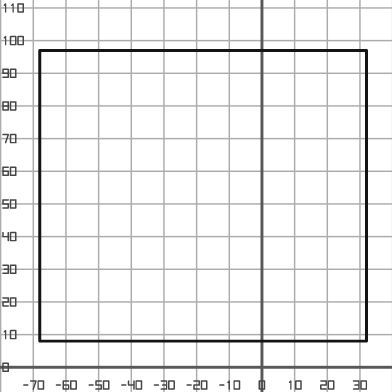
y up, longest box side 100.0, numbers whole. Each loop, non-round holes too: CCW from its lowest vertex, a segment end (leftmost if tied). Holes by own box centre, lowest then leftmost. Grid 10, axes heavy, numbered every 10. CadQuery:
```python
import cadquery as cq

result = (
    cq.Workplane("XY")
    .moveTo(-68.0, 8.0)
    .lineTo(32.0, 8.0)
    .lineTo(32.0, 97.0)
    .lineTo(-68.0, 97.0)
    .close()
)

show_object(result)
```